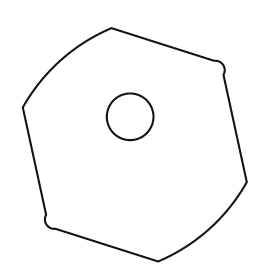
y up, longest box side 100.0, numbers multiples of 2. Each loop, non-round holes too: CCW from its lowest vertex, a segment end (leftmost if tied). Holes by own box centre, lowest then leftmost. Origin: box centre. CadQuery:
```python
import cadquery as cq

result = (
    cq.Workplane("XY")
    .moveTo(10.0, -50.0)
    .threePointArc((32.0, -36.0), (48.0, -16.0))
    .lineTo(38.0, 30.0)
    .threePointArc((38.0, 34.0), (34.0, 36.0))
    .lineTo(-10.0, 50.0)
    .threePointArc((-32.0, 36.0), (-48.0, 16.0))
    .lineTo(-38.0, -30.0)
    .threePointArc((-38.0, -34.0), (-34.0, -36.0))
    .close()
    .moveTo(-2.0, 12.0)
    .circle(10.0)
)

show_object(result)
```